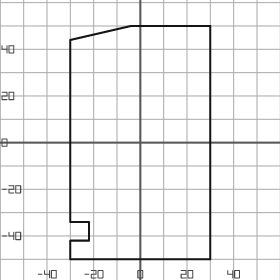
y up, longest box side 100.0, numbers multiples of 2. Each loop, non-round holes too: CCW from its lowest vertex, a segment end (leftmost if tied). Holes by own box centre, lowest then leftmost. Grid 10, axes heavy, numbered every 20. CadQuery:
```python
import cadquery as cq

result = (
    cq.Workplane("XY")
    .moveTo(-30.0, -50.0)
    .lineTo(30.0, -50.0)
    .lineTo(30.0, 50.0)
    .lineTo(-4.0, 50.0)
    .lineTo(-30.0, 44.0)
    .lineTo(-30.0, -34.0)
    .lineTo(-22.0, -34.0)
    .lineTo(-22.0, -42.0)
    .lineTo(-30.0, -42.0)
    .close()
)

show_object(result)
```